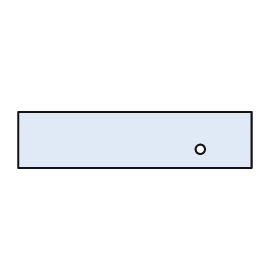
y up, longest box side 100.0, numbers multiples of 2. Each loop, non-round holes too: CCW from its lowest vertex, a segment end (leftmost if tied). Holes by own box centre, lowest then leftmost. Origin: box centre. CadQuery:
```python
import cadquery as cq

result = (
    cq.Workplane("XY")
    .moveTo(-50.0, -12.0)
    .lineTo(50.0, -12.0)
    .lineTo(50.0, 12.0)
    .lineTo(-50.0, 12.0)
    .close()
    .moveTo(28.0, -4.0)
    .circle(2.0)
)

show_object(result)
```